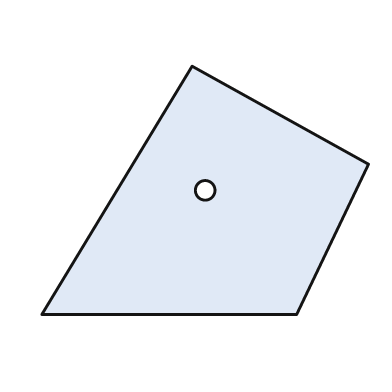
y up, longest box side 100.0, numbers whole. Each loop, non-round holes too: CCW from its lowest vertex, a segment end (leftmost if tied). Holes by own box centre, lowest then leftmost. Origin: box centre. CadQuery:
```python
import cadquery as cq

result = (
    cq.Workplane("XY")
    .moveTo(-50.0, -38.0)
    .lineTo(28.0, -38.0)
    .lineTo(50.0, 8.0)
    .lineTo(-4.0, 38.0)
    .close()
    .moveTo(0.0, 0.0)
    .circle(3.0)
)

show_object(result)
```